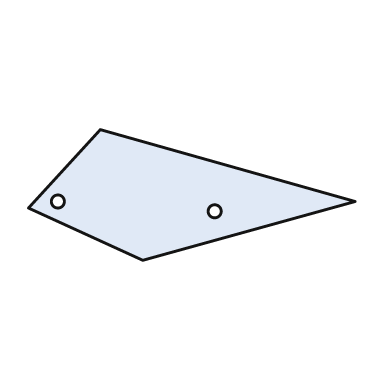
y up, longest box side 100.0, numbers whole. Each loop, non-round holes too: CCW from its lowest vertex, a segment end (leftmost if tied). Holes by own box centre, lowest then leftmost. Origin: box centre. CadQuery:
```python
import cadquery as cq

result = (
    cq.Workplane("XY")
    .moveTo(-15.0, -20.0)
    .lineTo(50.0, -2.0)
    .lineTo(-28.0, 20.0)
    .lineTo(-50.0, -4.0)
    .close()
    .moveTo(7.0, -5.0)
    .circle(2.0)
    .moveTo(-41.0, -2.0)
    .circle(2.0)
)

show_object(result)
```